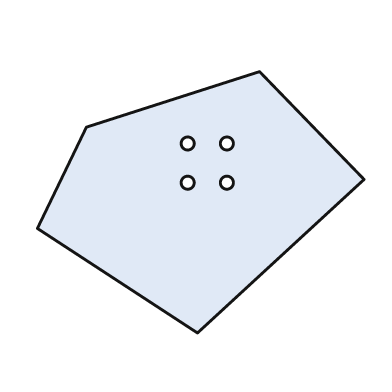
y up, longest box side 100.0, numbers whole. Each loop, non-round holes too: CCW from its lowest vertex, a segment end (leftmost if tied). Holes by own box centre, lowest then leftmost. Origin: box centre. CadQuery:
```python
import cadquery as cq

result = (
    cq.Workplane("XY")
    .moveTo(-1.0, -40.0)
    .lineTo(50.0, 7.0)
    .lineTo(18.0, 40.0)
    .lineTo(-35.0, 23.0)
    .lineTo(-50.0, -8.0)
    .close()
    .moveTo(-4.0, 6.0)
    .circle(2.0)
    .moveTo(8.0, 6.0)
    .circle(2.0)
    .moveTo(-4.0, 18.0)
    .circle(2.0)
    .moveTo(8.0, 18.0)
    .circle(2.0)
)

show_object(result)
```